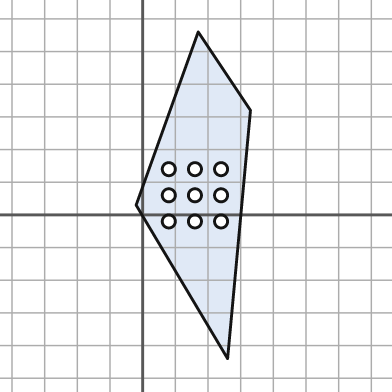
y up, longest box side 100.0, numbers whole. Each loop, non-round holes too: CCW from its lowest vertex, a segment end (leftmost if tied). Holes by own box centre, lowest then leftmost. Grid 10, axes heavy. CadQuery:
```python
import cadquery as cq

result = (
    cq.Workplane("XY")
    .moveTo(26.0, -44.0)
    .lineTo(33.0, 32.0)
    .lineTo(17.0, 56.0)
    .lineTo(-2.0, 3.0)
    .close()
    .moveTo(8.0, -2.0)
    .circle(2.0)
    .moveTo(16.0, -2.0)
    .circle(2.0)
    .moveTo(24.0, -2.0)
    .circle(2.0)
    .moveTo(8.0, 6.0)
    .circle(2.0)
    .moveTo(16.0, 6.0)
    .circle(2.0)
    .moveTo(24.0, 6.0)
    .circle(2.0)
    .moveTo(8.0, 14.0)
    .circle(2.0)
    .moveTo(16.0, 14.0)
    .circle(2.0)
    .moveTo(24.0, 14.0)
    .circle(2.0)
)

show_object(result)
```